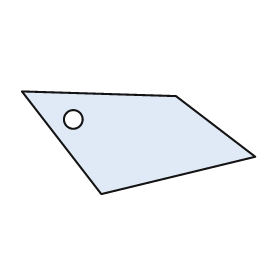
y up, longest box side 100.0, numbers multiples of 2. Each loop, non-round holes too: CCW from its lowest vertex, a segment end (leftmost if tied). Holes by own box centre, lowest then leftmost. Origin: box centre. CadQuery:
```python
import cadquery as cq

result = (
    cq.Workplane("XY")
    .moveTo(-16.0, -22.0)
    .lineTo(50.0, -6.0)
    .lineTo(16.0, 20.0)
    .lineTo(-50.0, 22.0)
    .close()
    .moveTo(-28.0, 10.0)
    .circle(4.0)
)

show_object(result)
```